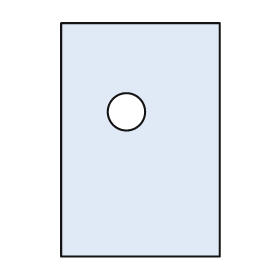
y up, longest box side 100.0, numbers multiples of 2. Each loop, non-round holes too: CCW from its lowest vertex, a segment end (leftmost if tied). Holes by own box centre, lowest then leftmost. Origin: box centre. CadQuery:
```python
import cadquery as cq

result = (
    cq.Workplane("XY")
    .moveTo(-34.0, -50.0)
    .lineTo(34.0, -50.0)
    .lineTo(34.0, 50.0)
    .lineTo(-34.0, 50.0)
    .close()
    .moveTo(-6.0, 12.0)
    .circle(8.0)
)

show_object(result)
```